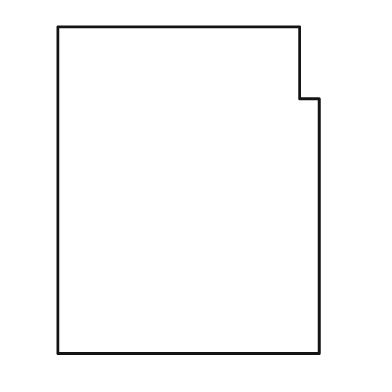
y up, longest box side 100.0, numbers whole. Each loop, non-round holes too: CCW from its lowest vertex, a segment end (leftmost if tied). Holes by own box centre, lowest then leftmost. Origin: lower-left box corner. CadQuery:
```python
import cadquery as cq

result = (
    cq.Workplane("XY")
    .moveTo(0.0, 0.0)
    .lineTo(80.0, 0.0)
    .lineTo(80.0, 78.0)
    .lineTo(74.0, 78.0)
    .lineTo(74.0, 100.0)
    .lineTo(0.0, 100.0)
    .close()
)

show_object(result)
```